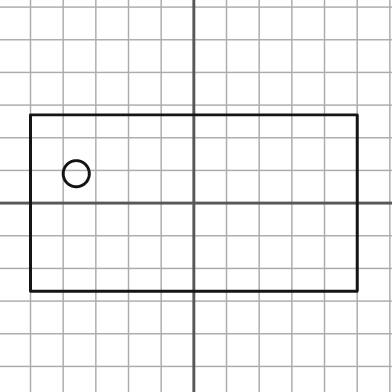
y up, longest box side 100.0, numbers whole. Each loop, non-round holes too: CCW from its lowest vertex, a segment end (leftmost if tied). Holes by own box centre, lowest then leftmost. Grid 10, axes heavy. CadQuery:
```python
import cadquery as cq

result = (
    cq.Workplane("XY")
    .moveTo(-50.0, -27.0)
    .lineTo(50.0, -27.0)
    .lineTo(50.0, 27.0)
    .lineTo(-50.0, 27.0)
    .close()
    .moveTo(-36.0, 9.0)
    .circle(4.0)
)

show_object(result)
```